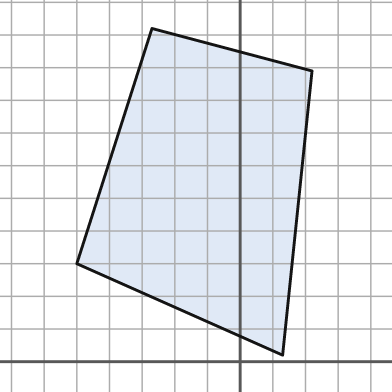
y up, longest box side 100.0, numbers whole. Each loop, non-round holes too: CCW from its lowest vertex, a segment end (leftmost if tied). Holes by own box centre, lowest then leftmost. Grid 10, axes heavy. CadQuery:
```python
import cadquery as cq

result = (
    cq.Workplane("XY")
    .moveTo(13.0, 2.0)
    .lineTo(22.0, 89.0)
    .lineTo(-27.0, 102.0)
    .lineTo(-50.0, 30.0)
    .close()
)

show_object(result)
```